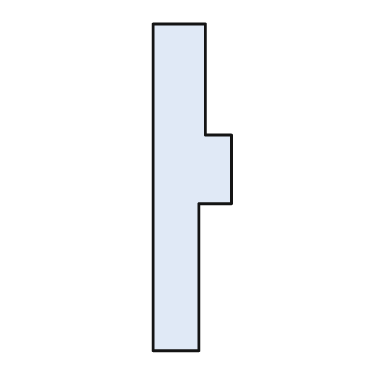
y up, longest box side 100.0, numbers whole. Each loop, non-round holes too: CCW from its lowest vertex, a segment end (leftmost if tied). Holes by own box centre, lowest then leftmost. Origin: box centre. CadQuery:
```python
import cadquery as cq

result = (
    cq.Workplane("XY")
    .moveTo(-12.0, -50.0)
    .lineTo(2.0, -50.0)
    .lineTo(2.0, -5.0)
    .lineTo(12.0, -5.0)
    .lineTo(12.0, 16.0)
    .lineTo(4.0, 16.0)
    .lineTo(4.0, 50.0)
    .lineTo(-12.0, 50.0)
    .close()
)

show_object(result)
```